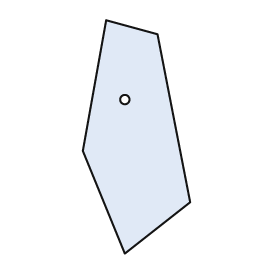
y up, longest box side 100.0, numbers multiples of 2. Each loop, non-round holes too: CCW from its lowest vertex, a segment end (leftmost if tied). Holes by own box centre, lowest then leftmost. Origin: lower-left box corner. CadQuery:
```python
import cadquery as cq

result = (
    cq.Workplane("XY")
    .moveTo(18.0, 0.0)
    .lineTo(46.0, 22.0)
    .lineTo(32.0, 94.0)
    .lineTo(10.0, 100.0)
    .lineTo(0.0, 44.0)
    .close()
    .moveTo(18.0, 66.0)
    .circle(2.0)
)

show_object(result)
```